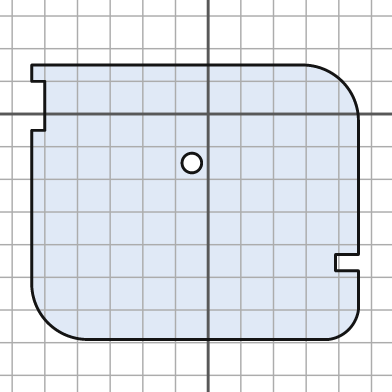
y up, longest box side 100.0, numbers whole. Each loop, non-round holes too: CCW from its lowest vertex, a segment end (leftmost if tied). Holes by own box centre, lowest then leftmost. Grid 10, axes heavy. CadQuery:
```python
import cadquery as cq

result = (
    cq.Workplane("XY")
    .moveTo(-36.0, -69.0)
    .lineTo(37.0, -69.0)
    .threePointArc((43.0, -66.0), (46.0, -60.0))
    .lineTo(46.0, -48.0)
    .lineTo(39.0, -48.0)
    .lineTo(39.0, -43.0)
    .lineTo(46.0, -43.0)
    .lineTo(46.0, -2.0)
    .threePointArc((41.0, 10.0), (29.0, 15.0))
    .lineTo(-54.0, 15.0)
    .lineTo(-54.0, 10.0)
    .lineTo(-50.0, 10.0)
    .lineTo(-50.0, -5.0)
    .lineTo(-54.0, -5.0)
    .lineTo(-54.0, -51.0)
    .threePointArc((-49.0, -64.0), (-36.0, -69.0))
    .close()
    .moveTo(-5.0, -15.0)
    .circle(3.0)
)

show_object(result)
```